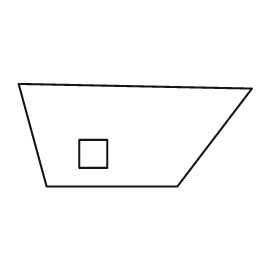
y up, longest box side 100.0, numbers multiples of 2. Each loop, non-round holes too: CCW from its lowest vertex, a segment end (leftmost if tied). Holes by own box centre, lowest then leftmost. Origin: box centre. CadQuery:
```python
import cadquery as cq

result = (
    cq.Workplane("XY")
    .moveTo(-38.0, -22.0)
    .lineTo(18.0, -22.0)
    .lineTo(50.0, 20.0)
    .lineTo(-50.0, 22.0)
    .close()
    .moveTo(-24.0, -14.0)
    .lineTo(-12.0, -14.0)
    .lineTo(-12.0, -2.0)
    .lineTo(-24.0, -2.0)
    .close()
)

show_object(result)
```